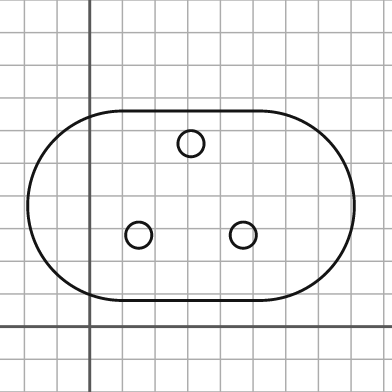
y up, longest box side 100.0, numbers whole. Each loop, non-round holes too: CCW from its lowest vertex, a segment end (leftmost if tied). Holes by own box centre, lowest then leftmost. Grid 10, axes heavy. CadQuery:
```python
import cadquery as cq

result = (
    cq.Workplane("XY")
    .moveTo(10.0, 8.0)
    .lineTo(52.0, 8.0)
    .threePointArc((81.0, 37.0), (52.0, 66.0))
    .lineTo(10.0, 66.0)
    .threePointArc((-19.0, 37.0), (10.0, 8.0))
    .close()
    .moveTo(15.0, 28.0)
    .circle(4.0)
    .moveTo(47.0, 28.0)
    .circle(4.0)
    .moveTo(31.0, 56.0)
    .circle(4.0)
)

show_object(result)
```